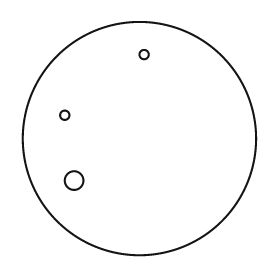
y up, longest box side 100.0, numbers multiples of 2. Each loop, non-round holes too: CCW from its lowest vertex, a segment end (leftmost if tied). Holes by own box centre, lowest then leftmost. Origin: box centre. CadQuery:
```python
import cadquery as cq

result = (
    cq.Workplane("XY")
    .moveTo(0.0, 0.0)
    .circle(50.0)
    .moveTo(-28.0, -18.0)
    .circle(4.0)
    .moveTo(-32.0, 10.0)
    .circle(2.0)
    .moveTo(2.0, 36.0)
    .circle(2.0)
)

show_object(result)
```